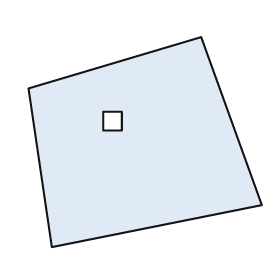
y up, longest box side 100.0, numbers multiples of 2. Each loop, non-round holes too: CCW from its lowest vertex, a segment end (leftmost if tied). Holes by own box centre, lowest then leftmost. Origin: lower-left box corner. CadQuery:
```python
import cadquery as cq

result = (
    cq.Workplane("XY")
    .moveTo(10.0, 0.0)
    .lineTo(100.0, 18.0)
    .lineTo(74.0, 90.0)
    .lineTo(0.0, 68.0)
    .close()
    .moveTo(32.0, 50.0)
    .lineTo(40.0, 50.0)
    .lineTo(40.0, 58.0)
    .lineTo(32.0, 58.0)
    .close()
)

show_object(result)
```